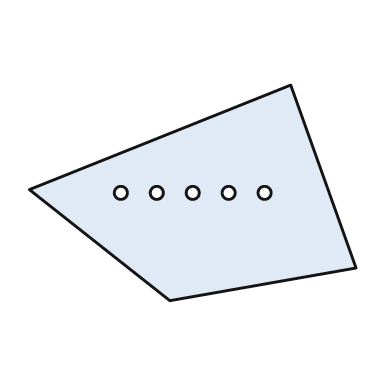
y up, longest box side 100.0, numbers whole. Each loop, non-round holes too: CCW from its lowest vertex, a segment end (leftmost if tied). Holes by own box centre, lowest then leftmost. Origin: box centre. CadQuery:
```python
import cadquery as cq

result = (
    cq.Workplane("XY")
    .moveTo(-7.0, -33.0)
    .lineTo(50.0, -23.0)
    .lineTo(30.0, 33.0)
    .lineTo(-50.0, 1.0)
    .close()
    .moveTo(-22.0, 0.0)
    .circle(2.0)
    .moveTo(-11.0, 0.0)
    .circle(2.0)
    .moveTo(0.0, 0.0)
    .circle(2.0)
    .moveTo(11.0, 0.0)
    .circle(2.0)
    .moveTo(22.0, 0.0)
    .circle(2.0)
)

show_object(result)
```